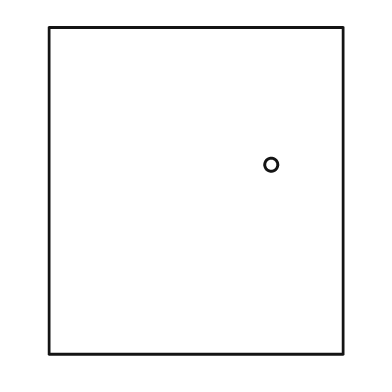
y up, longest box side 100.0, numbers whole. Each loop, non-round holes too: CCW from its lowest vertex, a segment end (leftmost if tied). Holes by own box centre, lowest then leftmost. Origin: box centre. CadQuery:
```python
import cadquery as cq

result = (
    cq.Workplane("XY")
    .moveTo(-45.0, -50.0)
    .lineTo(45.0, -50.0)
    .lineTo(45.0, 50.0)
    .lineTo(-45.0, 50.0)
    .close()
    .moveTo(23.0, 8.0)
    .circle(2.0)
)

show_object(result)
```